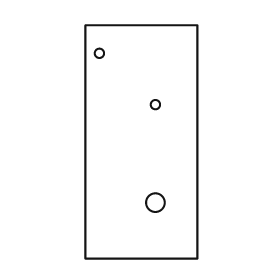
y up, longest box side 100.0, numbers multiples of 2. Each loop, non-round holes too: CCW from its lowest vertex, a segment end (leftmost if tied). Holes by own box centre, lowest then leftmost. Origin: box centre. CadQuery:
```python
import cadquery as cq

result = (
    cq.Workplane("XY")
    .moveTo(-24.0, -50.0)
    .lineTo(24.0, -50.0)
    .lineTo(24.0, 50.0)
    .lineTo(-24.0, 50.0)
    .close()
    .moveTo(6.0, -26.0)
    .circle(4.0)
    .moveTo(6.0, 16.0)
    .circle(2.0)
    .moveTo(-18.0, 38.0)
    .circle(2.0)
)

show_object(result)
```